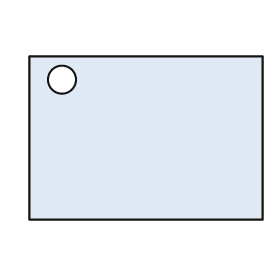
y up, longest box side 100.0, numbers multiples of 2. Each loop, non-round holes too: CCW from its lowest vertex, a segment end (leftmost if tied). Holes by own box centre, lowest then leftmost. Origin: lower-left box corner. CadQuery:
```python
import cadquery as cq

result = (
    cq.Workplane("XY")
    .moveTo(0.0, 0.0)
    .lineTo(100.0, 0.0)
    .lineTo(100.0, 70.0)
    .lineTo(0.0, 70.0)
    .close()
    .moveTo(14.0, 60.0)
    .circle(6.0)
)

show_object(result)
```